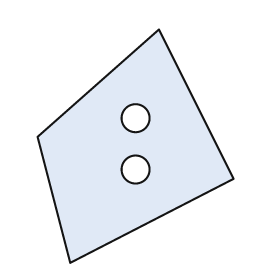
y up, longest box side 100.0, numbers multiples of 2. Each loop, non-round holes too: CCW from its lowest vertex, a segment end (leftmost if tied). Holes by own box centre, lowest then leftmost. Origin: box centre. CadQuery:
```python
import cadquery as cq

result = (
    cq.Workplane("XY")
    .moveTo(-28.0, -50.0)
    .lineTo(42.0, -14.0)
    .lineTo(10.0, 50.0)
    .lineTo(-42.0, 4.0)
    .close()
    .moveTo(0.0, -10.0)
    .circle(6.0)
    .moveTo(0.0, 12.0)
    .circle(6.0)
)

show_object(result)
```